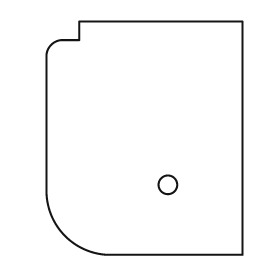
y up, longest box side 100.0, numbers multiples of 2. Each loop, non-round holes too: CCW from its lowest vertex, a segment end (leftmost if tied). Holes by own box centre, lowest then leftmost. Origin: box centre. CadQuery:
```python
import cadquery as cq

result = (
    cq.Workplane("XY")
    .moveTo(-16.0, -50.0)
    .lineTo(42.0, -50.0)
    .lineTo(42.0, 50.0)
    .lineTo(-28.0, 50.0)
    .lineTo(-28.0, 42.0)
    .lineTo(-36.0, 42.0)
    .threePointArc((-40.0, 40.0), (-42.0, 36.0))
    .lineTo(-42.0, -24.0)
    .threePointArc((-34.0, -42.0), (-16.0, -50.0))
    .close()
    .moveTo(10.0, -20.0)
    .circle(4.0)
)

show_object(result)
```